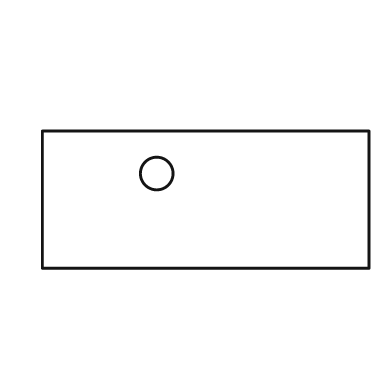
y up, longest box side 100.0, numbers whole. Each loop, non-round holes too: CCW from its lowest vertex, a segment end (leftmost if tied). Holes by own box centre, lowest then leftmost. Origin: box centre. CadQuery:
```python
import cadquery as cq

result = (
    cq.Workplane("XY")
    .moveTo(-50.0, -21.0)
    .lineTo(50.0, -21.0)
    .lineTo(50.0, 21.0)
    .lineTo(-50.0, 21.0)
    .close()
    .moveTo(-15.0, 8.0)
    .circle(5.0)
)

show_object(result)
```